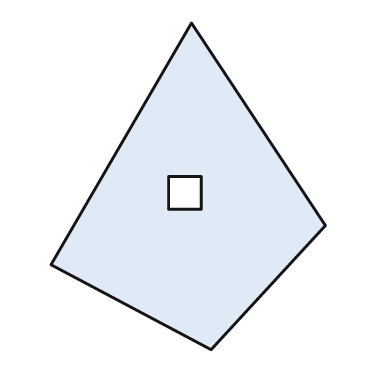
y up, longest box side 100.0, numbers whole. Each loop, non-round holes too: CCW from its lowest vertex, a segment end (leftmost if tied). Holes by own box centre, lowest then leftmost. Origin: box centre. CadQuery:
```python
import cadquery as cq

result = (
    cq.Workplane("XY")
    .moveTo(7.0, -50.0)
    .lineTo(42.0, -12.0)
    .lineTo(1.0, 50.0)
    .lineTo(-42.0, -24.0)
    .close()
    .moveTo(-6.0, -7.0)
    .lineTo(4.0, -7.0)
    .lineTo(4.0, 3.0)
    .lineTo(-6.0, 3.0)
    .close()
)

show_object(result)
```